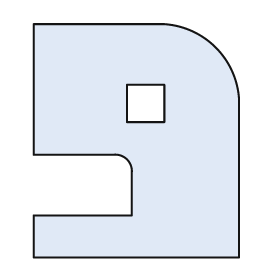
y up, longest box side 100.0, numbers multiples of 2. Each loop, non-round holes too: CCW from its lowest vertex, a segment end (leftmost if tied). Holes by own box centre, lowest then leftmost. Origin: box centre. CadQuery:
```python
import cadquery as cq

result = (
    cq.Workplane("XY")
    .moveTo(-44.0, -50.0)
    .lineTo(44.0, -50.0)
    .lineTo(44.0, 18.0)
    .threePointArc((34.0, 40.0), (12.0, 50.0))
    .lineTo(-44.0, 50.0)
    .lineTo(-44.0, -6.0)
    .lineTo(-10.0, -6.0)
    .threePointArc((-4.0, -8.0), (-2.0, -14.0))
    .lineTo(-2.0, -32.0)
    .lineTo(-44.0, -32.0)
    .close()
    .moveTo(-4.0, 8.0)
    .lineTo(12.0, 8.0)
    .lineTo(12.0, 24.0)
    .lineTo(-4.0, 24.0)
    .close()
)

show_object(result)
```